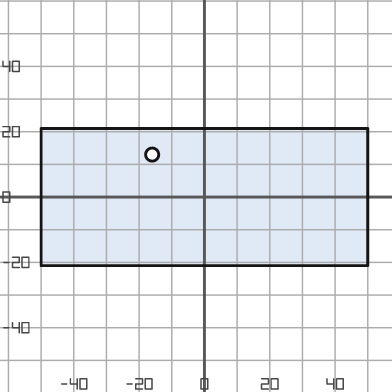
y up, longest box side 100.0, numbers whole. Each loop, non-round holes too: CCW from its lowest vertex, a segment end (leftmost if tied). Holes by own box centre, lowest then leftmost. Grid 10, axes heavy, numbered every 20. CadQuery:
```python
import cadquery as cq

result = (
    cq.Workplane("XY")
    .moveTo(-50.0, -21.0)
    .lineTo(50.0, -21.0)
    .lineTo(50.0, 21.0)
    .lineTo(-50.0, 21.0)
    .close()
    .moveTo(-16.0, 13.0)
    .circle(2.0)
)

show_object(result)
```